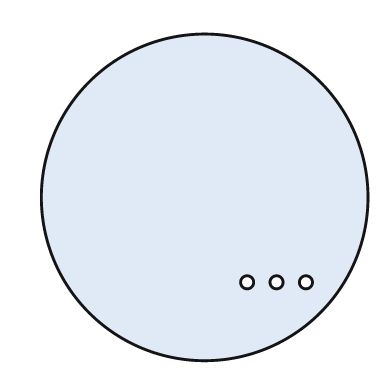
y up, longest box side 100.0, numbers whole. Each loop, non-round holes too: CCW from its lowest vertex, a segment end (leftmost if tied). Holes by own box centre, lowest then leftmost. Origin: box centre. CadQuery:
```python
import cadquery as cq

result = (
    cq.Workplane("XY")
    .moveTo(0.0, 0.0)
    .circle(50.0)
    .moveTo(13.0, -26.0)
    .circle(2.0)
    .moveTo(22.0, -26.0)
    .circle(2.0)
    .moveTo(31.0, -26.0)
    .circle(2.0)
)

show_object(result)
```